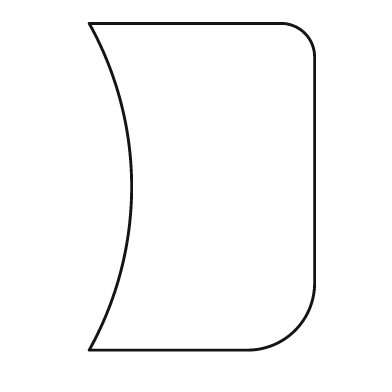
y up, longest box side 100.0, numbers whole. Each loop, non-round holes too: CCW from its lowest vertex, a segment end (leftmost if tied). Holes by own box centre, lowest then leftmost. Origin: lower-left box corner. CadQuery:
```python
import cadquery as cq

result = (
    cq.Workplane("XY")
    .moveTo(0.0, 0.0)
    .lineTo(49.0, 0.0)
    .threePointArc((63.0, 6.0), (69.0, 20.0))
    .lineTo(69.0, 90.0)
    .threePointArc((66.0, 97.0), (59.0, 100.0))
    .lineTo(0.0, 100.0)
    .threePointArc((13.0, 50.0), (0.0, 0.0))
    .close()
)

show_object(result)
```